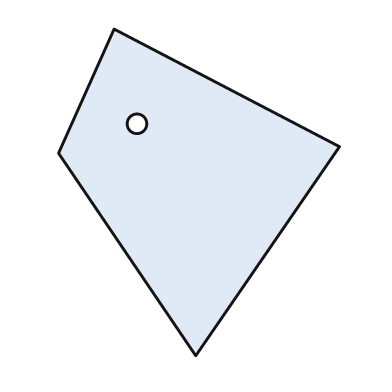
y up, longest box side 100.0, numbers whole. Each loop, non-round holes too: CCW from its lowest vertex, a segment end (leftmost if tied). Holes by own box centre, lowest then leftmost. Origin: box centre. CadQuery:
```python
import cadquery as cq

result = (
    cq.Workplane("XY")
    .moveTo(-1.0, -50.0)
    .lineTo(43.0, 14.0)
    .lineTo(-26.0, 50.0)
    .lineTo(-43.0, 12.0)
    .close()
    .moveTo(-19.0, 21.0)
    .circle(3.0)
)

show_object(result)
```